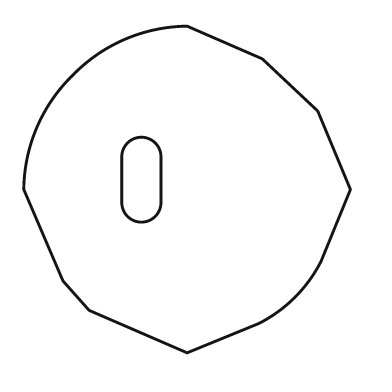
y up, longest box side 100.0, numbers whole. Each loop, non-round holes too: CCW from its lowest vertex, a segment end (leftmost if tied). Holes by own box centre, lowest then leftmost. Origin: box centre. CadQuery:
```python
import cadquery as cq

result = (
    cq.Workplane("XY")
    .moveTo(0.0, -50.0)
    .lineTo(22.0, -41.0)
    .threePointArc((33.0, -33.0), (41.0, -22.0))
    .lineTo(50.0, 0.0)
    .lineTo(40.0, 24.0)
    .lineTo(23.0, 40.0)
    .lineTo(0.0, 50.0)
    .threePointArc((-19.0, 46.0), (-35.0, 35.0))
    .threePointArc((-46.0, 19.0), (-50.0, 0.0))
    .lineTo(-38.0, -28.0)
    .lineTo(-30.0, -37.0)
    .close()
    .moveTo(-20.0, -4.0)
    .threePointArc((-14.0, -10.0), (-8.0, -4.0))
    .lineTo(-8.0, 10.0)
    .threePointArc((-14.0, 16.0), (-20.0, 10.0))
    .close()
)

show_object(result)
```